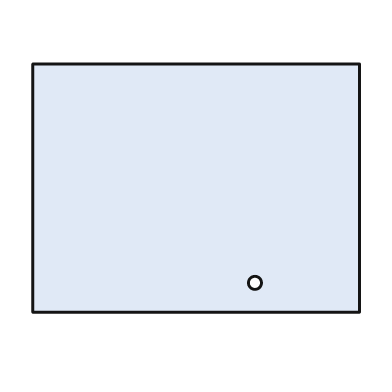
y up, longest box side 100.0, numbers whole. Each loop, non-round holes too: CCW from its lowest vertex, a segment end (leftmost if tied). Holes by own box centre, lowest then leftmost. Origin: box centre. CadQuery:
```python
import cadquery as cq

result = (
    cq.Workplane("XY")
    .moveTo(-50.0, -38.0)
    .lineTo(50.0, -38.0)
    .lineTo(50.0, 38.0)
    .lineTo(-50.0, 38.0)
    .close()
    .moveTo(18.0, -29.0)
    .circle(2.0)
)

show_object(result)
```